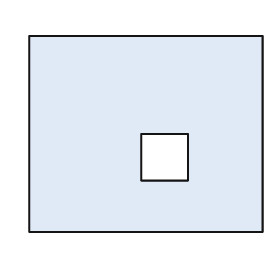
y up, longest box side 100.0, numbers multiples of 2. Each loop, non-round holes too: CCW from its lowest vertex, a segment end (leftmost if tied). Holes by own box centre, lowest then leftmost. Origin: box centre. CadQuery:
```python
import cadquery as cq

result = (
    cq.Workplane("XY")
    .moveTo(-50.0, -42.0)
    .lineTo(50.0, -42.0)
    .lineTo(50.0, 42.0)
    .lineTo(-50.0, 42.0)
    .close()
    .moveTo(-2.0, -20.0)
    .lineTo(18.0, -20.0)
    .lineTo(18.0, 0.0)
    .lineTo(-2.0, 0.0)
    .close()
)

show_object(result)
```